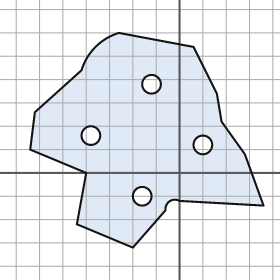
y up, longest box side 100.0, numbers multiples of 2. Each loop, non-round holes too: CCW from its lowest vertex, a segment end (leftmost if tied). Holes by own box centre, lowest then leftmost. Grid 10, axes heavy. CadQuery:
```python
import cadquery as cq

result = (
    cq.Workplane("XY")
    .moveTo(-20.0, -32.0)
    .lineTo(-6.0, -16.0)
    .threePointArc((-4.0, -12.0), (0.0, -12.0))
    .lineTo(36.0, -14.0)
    .lineTo(28.0, 8.0)
    .lineTo(18.0, 22.0)
    .lineTo(16.0, 34.0)
    .lineTo(6.0, 54.0)
    .lineTo(-26.0, 60.0)
    .threePointArc((-36.0, 54.0), (-42.0, 44.0))
    .lineTo(-62.0, 26.0)
    .lineTo(-64.0, 10.0)
    .lineTo(-40.0, 0.0)
    .lineTo(-44.0, -22.0)
    .close()
    .moveTo(-16.0, -10.0)
    .circle(4.0)
    .moveTo(10.0, 12.0)
    .circle(4.0)
    .moveTo(-38.0, 16.0)
    .circle(4.0)
    .moveTo(-12.0, 38.0)
    .circle(4.0)
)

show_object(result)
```